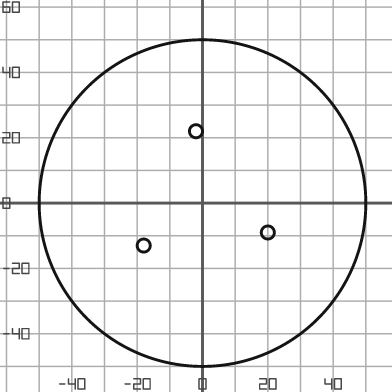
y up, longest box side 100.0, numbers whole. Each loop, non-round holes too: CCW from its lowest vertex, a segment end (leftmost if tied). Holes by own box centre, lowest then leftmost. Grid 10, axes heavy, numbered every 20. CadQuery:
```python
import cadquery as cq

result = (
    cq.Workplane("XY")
    .moveTo(0.0, 0.0)
    .circle(50.0)
    .moveTo(-18.0, -13.0)
    .circle(2.0)
    .moveTo(20.0, -9.0)
    .circle(2.0)
    .moveTo(-2.0, 22.0)
    .circle(2.0)
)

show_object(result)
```